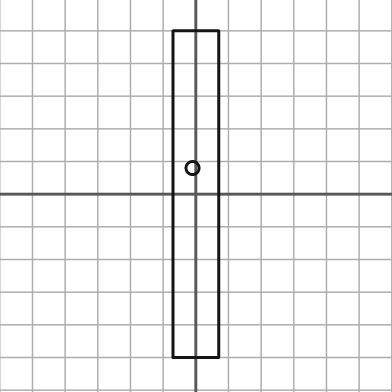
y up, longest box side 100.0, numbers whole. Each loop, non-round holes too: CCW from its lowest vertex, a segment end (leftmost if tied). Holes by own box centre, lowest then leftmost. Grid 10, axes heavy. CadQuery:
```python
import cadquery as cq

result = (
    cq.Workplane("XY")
    .moveTo(-7.0, -50.0)
    .lineTo(7.0, -50.0)
    .lineTo(7.0, 50.0)
    .lineTo(-7.0, 50.0)
    .close()
    .moveTo(-1.0, 8.0)
    .circle(2.0)
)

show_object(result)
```